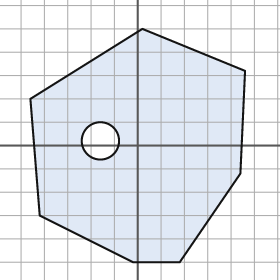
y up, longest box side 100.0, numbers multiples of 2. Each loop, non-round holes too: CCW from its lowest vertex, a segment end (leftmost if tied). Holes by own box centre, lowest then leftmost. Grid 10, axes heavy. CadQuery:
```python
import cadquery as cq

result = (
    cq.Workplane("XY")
    .moveTo(-2.0, -50.0)
    .lineTo(18.0, -50.0)
    .lineTo(44.0, -12.0)
    .lineTo(46.0, 32.0)
    .lineTo(2.0, 50.0)
    .lineTo(-46.0, 20.0)
    .lineTo(-42.0, -30.0)
    .close()
    .moveTo(-16.0, 2.0)
    .circle(8.0)
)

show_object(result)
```